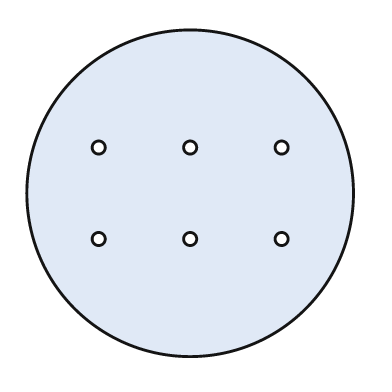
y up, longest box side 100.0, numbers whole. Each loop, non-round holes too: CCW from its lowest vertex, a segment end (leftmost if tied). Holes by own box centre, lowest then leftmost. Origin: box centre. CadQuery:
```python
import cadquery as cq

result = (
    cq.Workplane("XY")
    .moveTo(0.0, 0.0)
    .circle(50.0)
    .moveTo(-28.0, -14.0)
    .circle(2.0)
    .moveTo(0.0, -14.0)
    .circle(2.0)
    .moveTo(28.0, -14.0)
    .circle(2.0)
    .moveTo(-28.0, 14.0)
    .circle(2.0)
    .moveTo(0.0, 14.0)
    .circle(2.0)
    .moveTo(28.0, 14.0)
    .circle(2.0)
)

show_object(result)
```